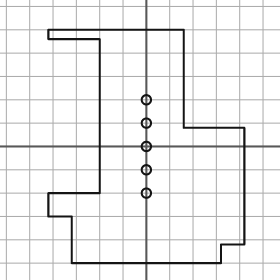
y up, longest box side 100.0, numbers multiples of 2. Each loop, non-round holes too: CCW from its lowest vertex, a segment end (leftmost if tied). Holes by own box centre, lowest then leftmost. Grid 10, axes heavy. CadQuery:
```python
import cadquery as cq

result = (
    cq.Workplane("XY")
    .moveTo(-32.0, -50.0)
    .lineTo(32.0, -50.0)
    .lineTo(32.0, -42.0)
    .lineTo(42.0, -42.0)
    .lineTo(42.0, 8.0)
    .lineTo(16.0, 8.0)
    .lineTo(16.0, 50.0)
    .lineTo(-42.0, 50.0)
    .lineTo(-42.0, 46.0)
    .lineTo(-20.0, 46.0)
    .lineTo(-20.0, -20.0)
    .lineTo(-42.0, -20.0)
    .lineTo(-42.0, -30.0)
    .lineTo(-32.0, -30.0)
    .close()
    .moveTo(0.0, -20.0)
    .circle(2.0)
    .moveTo(0.0, -10.0)
    .circle(2.0)
    .moveTo(0.0, 0.0)
    .circle(2.0)
    .moveTo(0.0, 10.0)
    .circle(2.0)
    .moveTo(0.0, 20.0)
    .circle(2.0)
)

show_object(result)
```